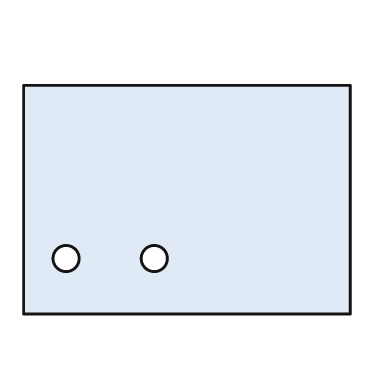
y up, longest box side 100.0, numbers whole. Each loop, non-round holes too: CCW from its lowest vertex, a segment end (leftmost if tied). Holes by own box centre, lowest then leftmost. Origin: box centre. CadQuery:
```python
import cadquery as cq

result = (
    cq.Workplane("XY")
    .moveTo(-50.0, -35.0)
    .lineTo(50.0, -35.0)
    .lineTo(50.0, 35.0)
    .lineTo(-50.0, 35.0)
    .close()
    .moveTo(-37.0, -18.0)
    .circle(4.0)
    .moveTo(-10.0, -18.0)
    .circle(4.0)
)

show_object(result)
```